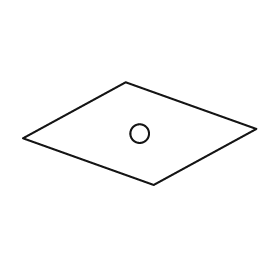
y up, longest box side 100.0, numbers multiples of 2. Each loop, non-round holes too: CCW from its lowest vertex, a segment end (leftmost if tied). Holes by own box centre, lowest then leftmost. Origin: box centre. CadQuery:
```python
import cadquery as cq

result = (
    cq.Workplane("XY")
    .moveTo(6.0, -22.0)
    .lineTo(50.0, 2.0)
    .lineTo(-6.0, 22.0)
    .lineTo(-50.0, -2.0)
    .close()
    .moveTo(0.0, 0.0)
    .circle(4.0)
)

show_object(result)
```